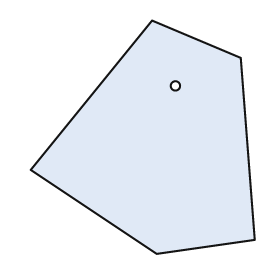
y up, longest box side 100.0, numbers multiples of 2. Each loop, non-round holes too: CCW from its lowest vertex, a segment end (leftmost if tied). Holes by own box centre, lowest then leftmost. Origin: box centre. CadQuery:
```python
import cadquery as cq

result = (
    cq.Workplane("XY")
    .moveTo(6.0, -50.0)
    .lineTo(48.0, -44.0)
    .lineTo(42.0, 34.0)
    .lineTo(4.0, 50.0)
    .lineTo(-48.0, -14.0)
    .close()
    .moveTo(14.0, 22.0)
    .circle(2.0)
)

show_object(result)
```